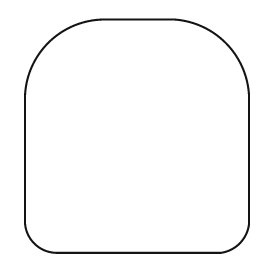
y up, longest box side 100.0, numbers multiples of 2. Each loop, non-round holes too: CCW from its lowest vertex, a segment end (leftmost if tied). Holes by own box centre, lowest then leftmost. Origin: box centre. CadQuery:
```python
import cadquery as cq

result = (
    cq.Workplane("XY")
    .moveTo(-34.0, -50.0)
    .lineTo(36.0, -50.0)
    .threePointArc((44.0, -46.0), (48.0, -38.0))
    .lineTo(48.0, 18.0)
    .threePointArc((38.0, 40.0), (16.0, 50.0))
    .lineTo(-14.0, 50.0)
    .threePointArc((-38.0, 40.0), (-48.0, 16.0))
    .lineTo(-48.0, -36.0)
    .threePointArc((-44.0, -46.0), (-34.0, -50.0))
    .close()
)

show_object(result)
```